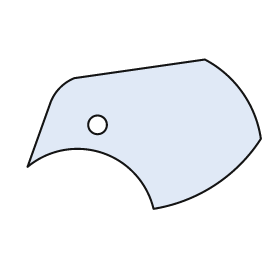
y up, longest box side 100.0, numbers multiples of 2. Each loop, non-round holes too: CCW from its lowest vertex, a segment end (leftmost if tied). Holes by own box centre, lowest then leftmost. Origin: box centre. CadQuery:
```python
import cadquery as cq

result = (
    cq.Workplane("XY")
    .moveTo(4.0, -32.0)
    .threePointArc((30.0, -22.0), (50.0, -2.0))
    .threePointArc((42.0, 18.0), (26.0, 32.0))
    .lineTo(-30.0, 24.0)
    .threePointArc((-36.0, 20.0), (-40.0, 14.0))
    .lineTo(-50.0, -14.0)
    .threePointArc((-18.0, -8.0), (4.0, -32.0))
    .close()
    .moveTo(-20.0, 4.0)
    .circle(4.0)
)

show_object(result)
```